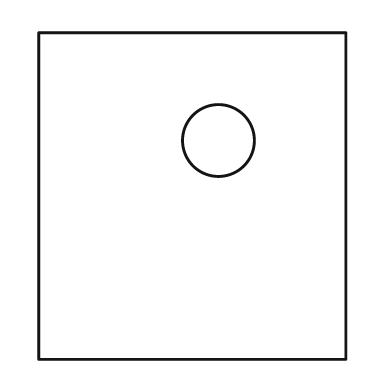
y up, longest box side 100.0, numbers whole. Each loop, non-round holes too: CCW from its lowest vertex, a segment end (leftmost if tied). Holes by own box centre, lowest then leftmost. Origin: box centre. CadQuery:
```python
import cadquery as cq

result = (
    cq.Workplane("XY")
    .moveTo(-47.0, -50.0)
    .lineTo(47.0, -50.0)
    .lineTo(47.0, 50.0)
    .lineTo(-47.0, 50.0)
    .close()
    .moveTo(8.0, 17.0)
    .circle(11.0)
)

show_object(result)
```